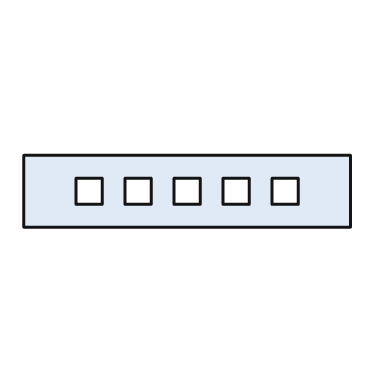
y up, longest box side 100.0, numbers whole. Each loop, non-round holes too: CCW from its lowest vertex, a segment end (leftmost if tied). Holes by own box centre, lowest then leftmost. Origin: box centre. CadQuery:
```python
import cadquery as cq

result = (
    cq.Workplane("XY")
    .moveTo(-50.0, -11.0)
    .lineTo(50.0, -11.0)
    .lineTo(50.0, 11.0)
    .lineTo(-50.0, 11.0)
    .close()
    .moveTo(-34.0, -4.0)
    .lineTo(-26.0, -4.0)
    .lineTo(-26.0, 4.0)
    .lineTo(-34.0, 4.0)
    .close()
    .moveTo(-19.0, -4.0)
    .lineTo(-11.0, -4.0)
    .lineTo(-11.0, 4.0)
    .lineTo(-19.0, 4.0)
    .close()
    .moveTo(-4.0, -4.0)
    .lineTo(4.0, -4.0)
    .lineTo(4.0, 4.0)
    .lineTo(-4.0, 4.0)
    .close()
    .moveTo(11.0, -4.0)
    .lineTo(19.0, -4.0)
    .lineTo(19.0, 4.0)
    .lineTo(11.0, 4.0)
    .close()
    .moveTo(26.0, -4.0)
    .lineTo(34.0, -4.0)
    .lineTo(34.0, 4.0)
    .lineTo(26.0, 4.0)
    .close()
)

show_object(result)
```